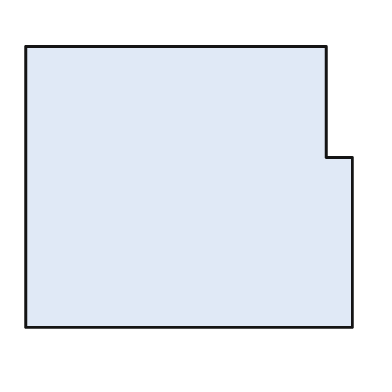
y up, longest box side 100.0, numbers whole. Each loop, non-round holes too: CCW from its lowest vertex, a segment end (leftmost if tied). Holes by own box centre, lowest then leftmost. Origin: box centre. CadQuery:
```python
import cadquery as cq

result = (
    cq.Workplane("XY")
    .moveTo(-50.0, -43.0)
    .lineTo(50.0, -43.0)
    .lineTo(50.0, 9.0)
    .lineTo(42.0, 9.0)
    .lineTo(42.0, 43.0)
    .lineTo(-50.0, 43.0)
    .close()
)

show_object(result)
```